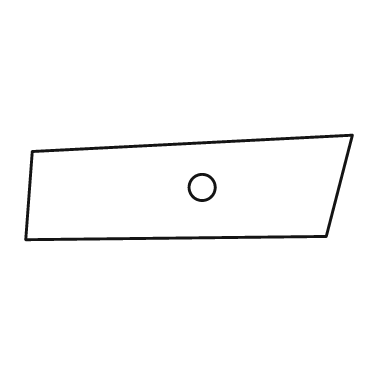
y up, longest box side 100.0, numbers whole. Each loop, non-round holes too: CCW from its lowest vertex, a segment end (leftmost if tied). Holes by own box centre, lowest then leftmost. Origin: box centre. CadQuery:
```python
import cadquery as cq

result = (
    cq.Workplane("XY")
    .moveTo(-50.0, -16.0)
    .lineTo(42.0, -15.0)
    .lineTo(50.0, 16.0)
    .lineTo(-48.0, 11.0)
    .close()
    .moveTo(4.0, 0.0)
    .circle(4.0)
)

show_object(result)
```